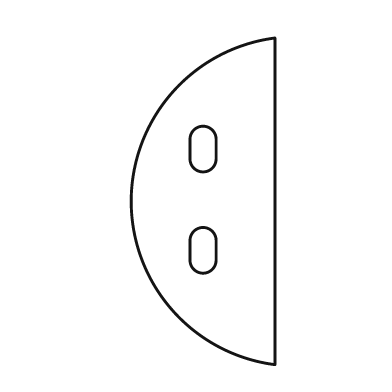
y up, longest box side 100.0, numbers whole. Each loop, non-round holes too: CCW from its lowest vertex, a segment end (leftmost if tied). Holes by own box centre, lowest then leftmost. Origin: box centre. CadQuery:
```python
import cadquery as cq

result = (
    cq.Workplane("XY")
    .moveTo(22.0, -50.0)
    .lineTo(22.0, 50.0)
    .threePointArc((-22.0, 0.0), (22.0, -50.0))
    .close()
    .moveTo(-4.0, -18.0)
    .threePointArc((0.0, -22.0), (4.0, -18.0))
    .lineTo(4.0, -12.0)
    .threePointArc((0.0, -8.0), (-4.0, -12.0))
    .close()
    .moveTo(-4.0, 13.0)
    .threePointArc((0.0, 9.0), (4.0, 13.0))
    .lineTo(4.0, 19.0)
    .threePointArc((0.0, 23.0), (-4.0, 19.0))
    .close()
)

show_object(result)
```